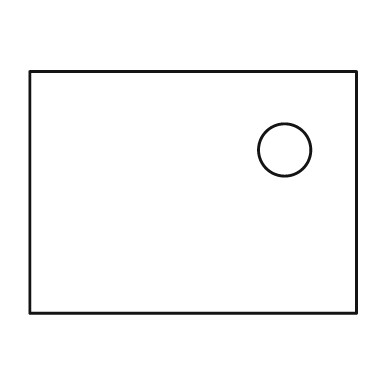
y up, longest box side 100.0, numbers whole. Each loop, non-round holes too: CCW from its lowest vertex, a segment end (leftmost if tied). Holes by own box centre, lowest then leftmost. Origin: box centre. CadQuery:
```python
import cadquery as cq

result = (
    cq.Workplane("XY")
    .moveTo(-50.0, -37.0)
    .lineTo(50.0, -37.0)
    .lineTo(50.0, 37.0)
    .lineTo(-50.0, 37.0)
    .close()
    .moveTo(28.0, 13.0)
    .circle(8.0)
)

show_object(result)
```